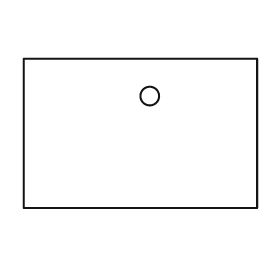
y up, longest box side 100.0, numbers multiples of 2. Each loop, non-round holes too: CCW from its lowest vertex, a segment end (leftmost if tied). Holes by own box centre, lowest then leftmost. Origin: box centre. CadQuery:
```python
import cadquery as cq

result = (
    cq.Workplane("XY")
    .moveTo(-50.0, -32.0)
    .lineTo(50.0, -32.0)
    .lineTo(50.0, 32.0)
    .lineTo(-50.0, 32.0)
    .close()
    .moveTo(4.0, 16.0)
    .circle(4.0)
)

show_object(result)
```